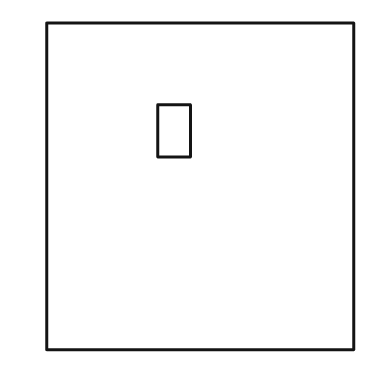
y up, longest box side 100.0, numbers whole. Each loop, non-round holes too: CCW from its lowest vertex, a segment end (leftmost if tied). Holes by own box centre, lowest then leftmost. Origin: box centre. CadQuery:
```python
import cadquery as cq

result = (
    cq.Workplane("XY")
    .moveTo(-47.0, -50.0)
    .lineTo(47.0, -50.0)
    .lineTo(47.0, 50.0)
    .lineTo(-47.0, 50.0)
    .close()
    .moveTo(-13.0, 9.0)
    .lineTo(-3.0, 9.0)
    .lineTo(-3.0, 25.0)
    .lineTo(-13.0, 25.0)
    .close()
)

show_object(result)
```